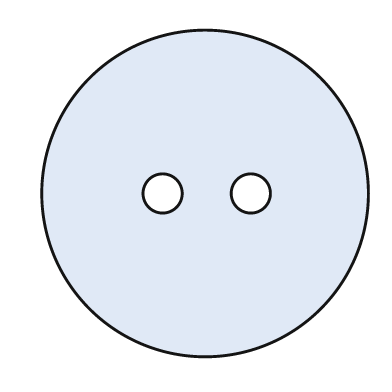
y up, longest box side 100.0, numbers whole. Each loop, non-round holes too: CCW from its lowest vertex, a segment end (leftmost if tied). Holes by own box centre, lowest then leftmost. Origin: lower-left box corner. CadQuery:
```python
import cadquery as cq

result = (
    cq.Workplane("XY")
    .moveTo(50.0, 50.0)
    .circle(50.0)
    .moveTo(37.0, 50.0)
    .circle(6.0)
    .moveTo(64.0, 50.0)
    .circle(6.0)
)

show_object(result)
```